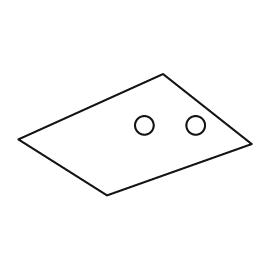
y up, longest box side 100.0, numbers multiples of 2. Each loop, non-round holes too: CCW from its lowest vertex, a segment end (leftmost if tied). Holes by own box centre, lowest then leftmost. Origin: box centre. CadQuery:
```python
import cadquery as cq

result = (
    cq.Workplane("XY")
    .moveTo(-12.0, -26.0)
    .lineTo(50.0, -4.0)
    .lineTo(12.0, 26.0)
    .lineTo(-50.0, -2.0)
    .close()
    .moveTo(4.0, 4.0)
    .circle(4.0)
    .moveTo(26.0, 4.0)
    .circle(4.0)
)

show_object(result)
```